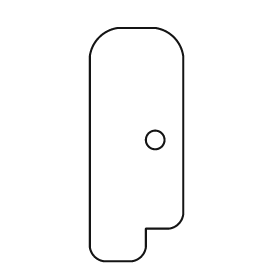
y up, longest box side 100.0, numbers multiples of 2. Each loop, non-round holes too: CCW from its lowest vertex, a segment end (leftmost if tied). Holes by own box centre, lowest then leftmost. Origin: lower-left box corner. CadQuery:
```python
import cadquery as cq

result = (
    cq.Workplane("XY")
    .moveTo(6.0, 0.0)
    .lineTo(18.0, 0.0)
    .threePointArc((22.0, 2.0), (24.0, 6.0))
    .lineTo(24.0, 14.0)
    .lineTo(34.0, 14.0)
    .threePointArc((38.0, 16.0), (40.0, 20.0))
    .lineTo(40.0, 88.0)
    .threePointArc((36.0, 96.0), (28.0, 100.0))
    .lineTo(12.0, 100.0)
    .threePointArc((4.0, 96.0), (0.0, 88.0))
    .lineTo(0.0, 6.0)
    .threePointArc((2.0, 2.0), (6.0, 0.0))
    .close()
    .moveTo(28.0, 52.0)
    .circle(4.0)
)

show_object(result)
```